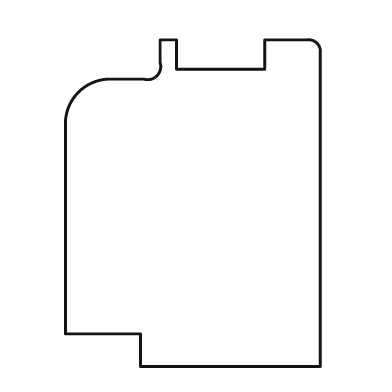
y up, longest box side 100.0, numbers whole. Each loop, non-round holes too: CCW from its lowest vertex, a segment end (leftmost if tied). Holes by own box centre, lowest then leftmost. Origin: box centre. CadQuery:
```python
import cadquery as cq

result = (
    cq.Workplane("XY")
    .moveTo(-16.0, -50.0)
    .lineTo(39.0, -50.0)
    .lineTo(39.0, 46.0)
    .threePointArc((38.0, 49.0), (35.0, 50.0))
    .lineTo(22.0, 50.0)
    .lineTo(22.0, 41.0)
    .lineTo(-5.0, 41.0)
    .lineTo(-5.0, 50.0)
    .lineTo(-10.0, 50.0)
    .lineTo(-10.0, 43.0)
    .threePointArc((-11.0, 39.0), (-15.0, 38.0))
    .lineTo(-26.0, 38.0)
    .threePointArc((-35.0, 34.0), (-39.0, 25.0))
    .lineTo(-39.0, -40.0)
    .lineTo(-16.0, -40.0)
    .close()
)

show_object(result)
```